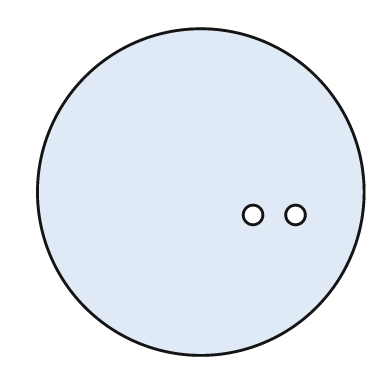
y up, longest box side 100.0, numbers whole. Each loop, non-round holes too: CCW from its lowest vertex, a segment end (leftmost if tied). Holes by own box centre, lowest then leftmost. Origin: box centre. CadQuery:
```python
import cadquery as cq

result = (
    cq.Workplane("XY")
    .moveTo(0.0, 0.0)
    .circle(50.0)
    .moveTo(16.0, -7.0)
    .circle(3.0)
    .moveTo(29.0, -7.0)
    .circle(3.0)
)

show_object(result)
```